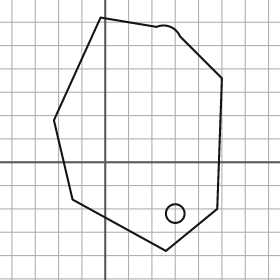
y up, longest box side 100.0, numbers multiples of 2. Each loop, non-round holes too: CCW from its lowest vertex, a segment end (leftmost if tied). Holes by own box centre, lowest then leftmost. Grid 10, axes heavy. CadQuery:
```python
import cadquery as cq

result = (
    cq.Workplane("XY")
    .moveTo(26.0, -38.0)
    .lineTo(48.0, -20.0)
    .lineTo(50.0, 36.0)
    .lineTo(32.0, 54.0)
    .threePointArc((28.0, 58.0), (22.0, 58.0))
    .lineTo(-2.0, 62.0)
    .lineTo(-22.0, 18.0)
    .lineTo(-14.0, -16.0)
    .close()
    .moveTo(30.0, -22.0)
    .circle(4.0)
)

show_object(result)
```